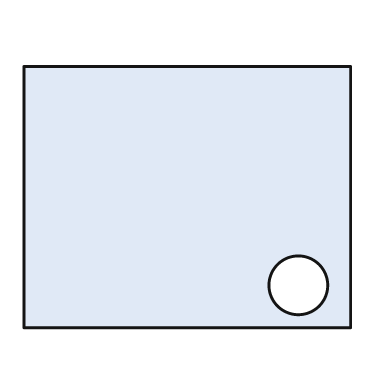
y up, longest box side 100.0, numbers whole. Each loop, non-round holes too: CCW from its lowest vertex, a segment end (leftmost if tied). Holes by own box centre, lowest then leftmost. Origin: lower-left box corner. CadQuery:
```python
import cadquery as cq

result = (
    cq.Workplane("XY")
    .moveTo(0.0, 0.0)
    .lineTo(100.0, 0.0)
    .lineTo(100.0, 80.0)
    .lineTo(0.0, 80.0)
    .close()
    .moveTo(84.0, 13.0)
    .circle(9.0)
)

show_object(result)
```